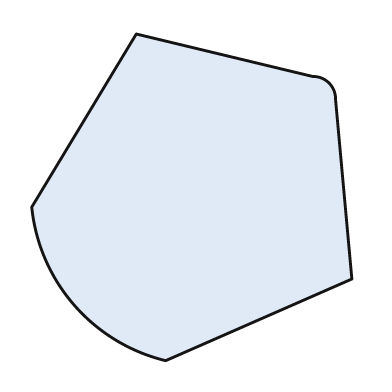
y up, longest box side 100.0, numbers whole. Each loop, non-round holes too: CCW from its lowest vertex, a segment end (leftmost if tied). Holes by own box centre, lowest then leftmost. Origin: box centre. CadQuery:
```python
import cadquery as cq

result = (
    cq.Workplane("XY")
    .moveTo(-8.0, -50.0)
    .lineTo(49.0, -25.0)
    .lineTo(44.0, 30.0)
    .threePointArc((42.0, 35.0), (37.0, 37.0))
    .lineTo(-17.0, 50.0)
    .lineTo(-49.0, -3.0)
    .threePointArc((-36.0, -33.0), (-8.0, -50.0))
    .close()
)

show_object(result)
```